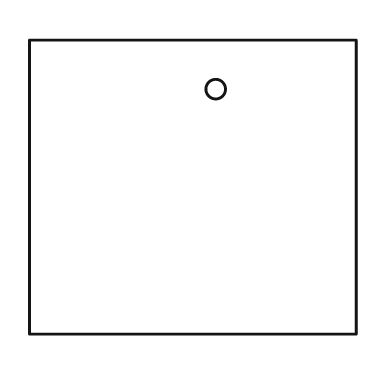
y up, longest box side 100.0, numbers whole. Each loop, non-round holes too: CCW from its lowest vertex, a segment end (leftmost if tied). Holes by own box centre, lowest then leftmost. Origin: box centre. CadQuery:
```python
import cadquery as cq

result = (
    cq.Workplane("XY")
    .moveTo(-50.0, -45.0)
    .lineTo(50.0, -45.0)
    .lineTo(50.0, 45.0)
    .lineTo(-50.0, 45.0)
    .close()
    .moveTo(7.0, 30.0)
    .circle(3.0)
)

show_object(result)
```